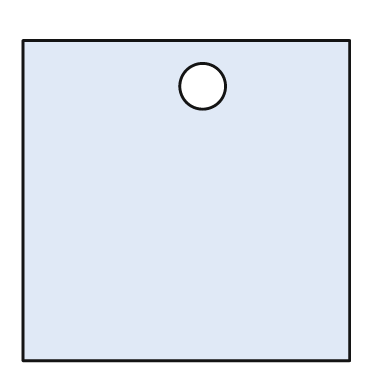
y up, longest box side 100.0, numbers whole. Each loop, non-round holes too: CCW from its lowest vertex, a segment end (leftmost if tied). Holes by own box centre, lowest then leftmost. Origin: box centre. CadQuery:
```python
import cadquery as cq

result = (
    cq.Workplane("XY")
    .moveTo(-50.0, -49.0)
    .lineTo(50.0, -49.0)
    .lineTo(50.0, 49.0)
    .lineTo(-50.0, 49.0)
    .close()
    .moveTo(5.0, 35.0)
    .circle(7.0)
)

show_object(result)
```